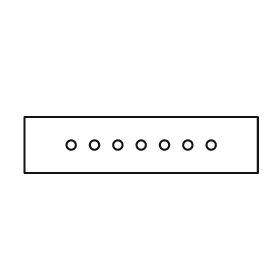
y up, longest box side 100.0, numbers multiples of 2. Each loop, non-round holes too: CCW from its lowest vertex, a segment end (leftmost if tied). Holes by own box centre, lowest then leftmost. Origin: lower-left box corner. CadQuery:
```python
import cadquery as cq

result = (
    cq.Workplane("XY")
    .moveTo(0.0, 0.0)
    .lineTo(100.0, 0.0)
    .lineTo(100.0, 24.0)
    .lineTo(0.0, 24.0)
    .close()
    .moveTo(20.0, 12.0)
    .circle(2.0)
    .moveTo(30.0, 12.0)
    .circle(2.0)
    .moveTo(40.0, 12.0)
    .circle(2.0)
    .moveTo(50.0, 12.0)
    .circle(2.0)
    .moveTo(60.0, 12.0)
    .circle(2.0)
    .moveTo(70.0, 12.0)
    .circle(2.0)
    .moveTo(80.0, 12.0)
    .circle(2.0)
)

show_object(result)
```